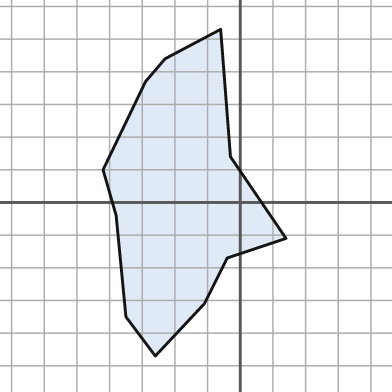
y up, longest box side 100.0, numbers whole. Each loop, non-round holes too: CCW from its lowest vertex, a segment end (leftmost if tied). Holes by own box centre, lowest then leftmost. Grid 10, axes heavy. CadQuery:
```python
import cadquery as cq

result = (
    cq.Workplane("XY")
    .moveTo(-26.0, -47.0)
    .lineTo(-11.0, -31.0)
    .lineTo(-4.0, -17.0)
    .lineTo(14.0, -11.0)
    .lineTo(-3.0, 14.0)
    .lineTo(-6.0, 53.0)
    .lineTo(-23.0, 44.0)
    .lineTo(-29.0, 37.0)
    .lineTo(-42.0, 10.0)
    .lineTo(-38.0, -4.0)
    .lineTo(-35.0, -35.0)
    .close()
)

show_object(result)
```